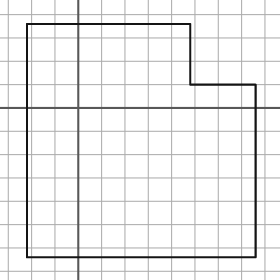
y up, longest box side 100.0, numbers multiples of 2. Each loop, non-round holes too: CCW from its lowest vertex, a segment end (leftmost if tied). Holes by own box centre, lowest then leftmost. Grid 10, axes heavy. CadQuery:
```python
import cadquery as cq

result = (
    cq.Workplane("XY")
    .moveTo(-22.0, -64.0)
    .lineTo(76.0, -64.0)
    .lineTo(76.0, 10.0)
    .lineTo(48.0, 10.0)
    .lineTo(48.0, 36.0)
    .lineTo(-22.0, 36.0)
    .close()
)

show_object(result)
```